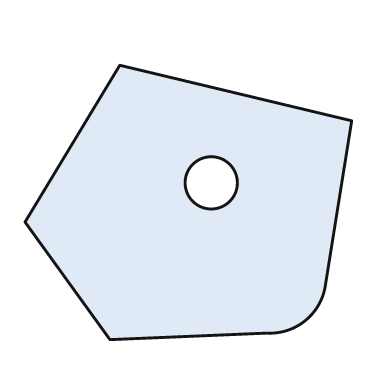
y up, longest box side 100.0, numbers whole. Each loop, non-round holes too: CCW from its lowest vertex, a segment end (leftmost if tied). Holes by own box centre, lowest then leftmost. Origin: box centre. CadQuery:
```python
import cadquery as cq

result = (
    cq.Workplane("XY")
    .moveTo(-24.0, -42.0)
    .lineTo(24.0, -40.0)
    .threePointArc((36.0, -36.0), (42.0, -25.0))
    .lineTo(50.0, 25.0)
    .lineTo(-21.0, 42.0)
    .lineTo(-50.0, -6.0)
    .close()
    .moveTo(7.0, 6.0)
    .circle(8.0)
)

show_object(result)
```